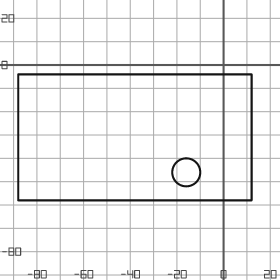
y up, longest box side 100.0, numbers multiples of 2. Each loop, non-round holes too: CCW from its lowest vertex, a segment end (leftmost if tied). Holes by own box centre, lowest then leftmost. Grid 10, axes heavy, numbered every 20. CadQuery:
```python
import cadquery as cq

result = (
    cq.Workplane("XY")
    .moveTo(-88.0, -58.0)
    .lineTo(12.0, -58.0)
    .lineTo(12.0, -4.0)
    .lineTo(-88.0, -4.0)
    .close()
    .moveTo(-16.0, -46.0)
    .circle(6.0)
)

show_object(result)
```